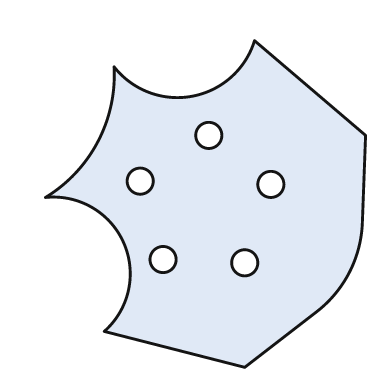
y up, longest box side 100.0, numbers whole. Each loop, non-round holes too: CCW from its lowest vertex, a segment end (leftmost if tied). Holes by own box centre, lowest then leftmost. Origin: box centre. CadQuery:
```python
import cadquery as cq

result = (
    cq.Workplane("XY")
    .moveTo(12.0, -50.0)
    .lineTo(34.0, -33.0)
    .threePointArc((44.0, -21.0), (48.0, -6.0))
    .lineTo(49.0, 21.0)
    .lineTo(15.0, 50.0)
    .threePointArc((-4.0, 33.0), (-28.0, 42.0))
    .threePointArc((-33.0, 19.0), (-49.0, 2.0))
    .threePointArc((-25.0, -12.0), (-31.0, -39.0))
    .close()
    .moveTo(12.0, -18.0)
    .circle(4.0)
    .moveTo(-13.0, -17.0)
    .circle(4.0)
    .moveTo(20.0, 6.0)
    .circle(4.0)
    .moveTo(-20.0, 7.0)
    .circle(4.0)
    .moveTo(1.0, 21.0)
    .circle(4.0)
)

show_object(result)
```